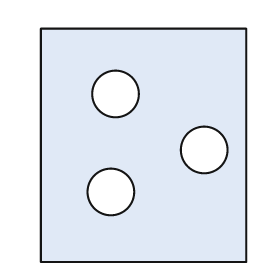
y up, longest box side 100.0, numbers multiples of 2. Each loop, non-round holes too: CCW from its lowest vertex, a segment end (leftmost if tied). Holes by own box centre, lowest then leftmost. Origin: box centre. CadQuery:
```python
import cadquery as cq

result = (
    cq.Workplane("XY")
    .moveTo(-44.0, -50.0)
    .lineTo(44.0, -50.0)
    .lineTo(44.0, 50.0)
    .lineTo(-44.0, 50.0)
    .close()
    .moveTo(-14.0, -20.0)
    .circle(10.0)
    .moveTo(26.0, -2.0)
    .circle(10.0)
    .moveTo(-12.0, 22.0)
    .circle(10.0)
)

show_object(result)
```